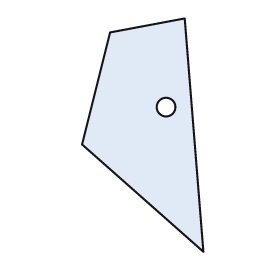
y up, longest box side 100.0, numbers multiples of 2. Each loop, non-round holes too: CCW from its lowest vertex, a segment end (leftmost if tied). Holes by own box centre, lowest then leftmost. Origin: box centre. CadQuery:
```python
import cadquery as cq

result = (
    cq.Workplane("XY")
    .moveTo(26.0, -50.0)
    .lineTo(18.0, 50.0)
    .lineTo(-14.0, 44.0)
    .lineTo(-26.0, -4.0)
    .close()
    .moveTo(10.0, 12.0)
    .circle(4.0)
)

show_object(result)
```